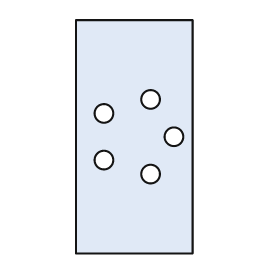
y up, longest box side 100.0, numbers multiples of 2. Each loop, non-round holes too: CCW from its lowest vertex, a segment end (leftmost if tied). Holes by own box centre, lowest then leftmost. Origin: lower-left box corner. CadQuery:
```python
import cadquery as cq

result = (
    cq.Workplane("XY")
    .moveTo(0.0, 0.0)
    .lineTo(50.0, 0.0)
    .lineTo(50.0, 100.0)
    .lineTo(0.0, 100.0)
    .close()
    .moveTo(32.0, 34.0)
    .circle(4.0)
    .moveTo(12.0, 40.0)
    .circle(4.0)
    .moveTo(42.0, 50.0)
    .circle(4.0)
    .moveTo(12.0, 60.0)
    .circle(4.0)
    .moveTo(32.0, 66.0)
    .circle(4.0)
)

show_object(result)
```